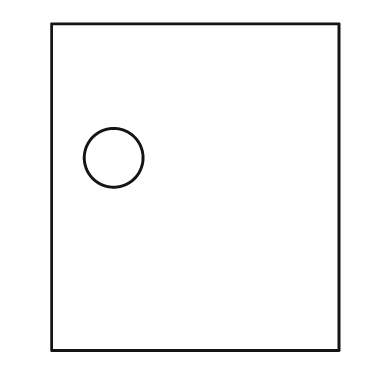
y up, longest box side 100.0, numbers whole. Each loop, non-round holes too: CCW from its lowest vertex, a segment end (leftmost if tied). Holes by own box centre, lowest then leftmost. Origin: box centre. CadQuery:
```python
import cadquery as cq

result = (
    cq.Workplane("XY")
    .moveTo(-44.0, -50.0)
    .lineTo(44.0, -50.0)
    .lineTo(44.0, 50.0)
    .lineTo(-44.0, 50.0)
    .close()
    .moveTo(-25.0, 9.0)
    .circle(9.0)
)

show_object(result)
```